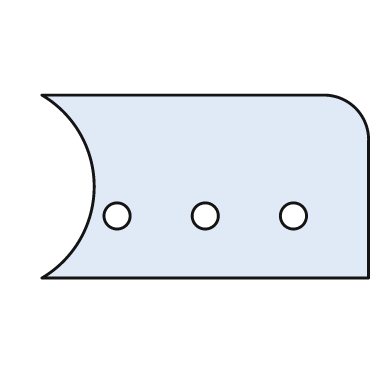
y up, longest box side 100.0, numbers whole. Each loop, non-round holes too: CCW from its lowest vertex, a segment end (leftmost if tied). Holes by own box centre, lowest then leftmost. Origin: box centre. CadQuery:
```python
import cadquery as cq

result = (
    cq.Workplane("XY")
    .moveTo(-50.0, -28.0)
    .lineTo(50.0, -28.0)
    .lineTo(50.0, 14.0)
    .threePointArc((46.0, 24.0), (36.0, 28.0))
    .lineTo(-50.0, 28.0)
    .threePointArc((-34.0, 0.0), (-50.0, -28.0))
    .close()
    .moveTo(-27.0, -9.0)
    .circle(4.0)
    .moveTo(0.0, -9.0)
    .circle(4.0)
    .moveTo(27.0, -9.0)
    .circle(4.0)
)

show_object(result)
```